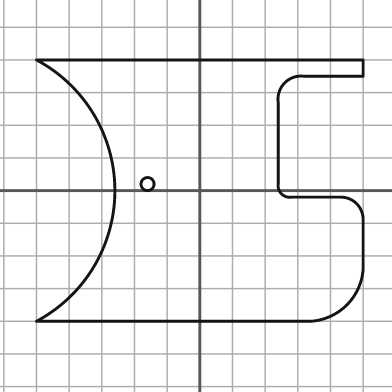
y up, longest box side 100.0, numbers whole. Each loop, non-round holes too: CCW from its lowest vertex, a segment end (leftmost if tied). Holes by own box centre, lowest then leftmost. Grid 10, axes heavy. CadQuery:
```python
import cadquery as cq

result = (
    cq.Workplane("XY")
    .moveTo(-50.0, -40.0)
    .lineTo(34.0, -40.0)
    .threePointArc((45.0, -35.0), (50.0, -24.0))
    .lineTo(50.0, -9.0)
    .threePointArc((48.0, -4.0), (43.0, -2.0))
    .lineTo(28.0, -2.0)
    .threePointArc((25.0, -1.0), (24.0, 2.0))
    .lineTo(24.0, 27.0)
    .threePointArc((26.0, 33.0), (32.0, 35.0))
    .lineTo(50.0, 35.0)
    .lineTo(50.0, 40.0)
    .lineTo(-50.0, 40.0)
    .threePointArc((-26.0, 0.0), (-50.0, -40.0))
    .close()
    .moveTo(-16.0, 2.0)
    .circle(2.0)
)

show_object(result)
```